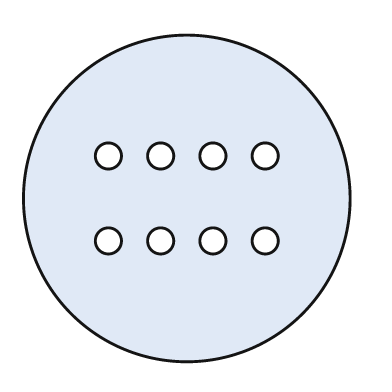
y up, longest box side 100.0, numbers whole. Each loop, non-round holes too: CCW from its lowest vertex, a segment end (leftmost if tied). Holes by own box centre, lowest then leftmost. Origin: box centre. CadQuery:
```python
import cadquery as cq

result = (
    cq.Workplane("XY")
    .moveTo(0.0, 0.0)
    .circle(50.0)
    .moveTo(-24.0, -13.0)
    .circle(4.0)
    .moveTo(-8.0, -13.0)
    .circle(4.0)
    .moveTo(8.0, -13.0)
    .circle(4.0)
    .moveTo(24.0, -13.0)
    .circle(4.0)
    .moveTo(-24.0, 13.0)
    .circle(4.0)
    .moveTo(-8.0, 13.0)
    .circle(4.0)
    .moveTo(8.0, 13.0)
    .circle(4.0)
    .moveTo(24.0, 13.0)
    .circle(4.0)
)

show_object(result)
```